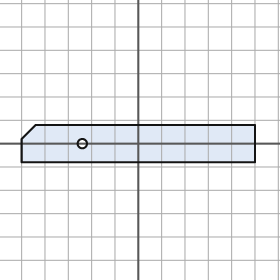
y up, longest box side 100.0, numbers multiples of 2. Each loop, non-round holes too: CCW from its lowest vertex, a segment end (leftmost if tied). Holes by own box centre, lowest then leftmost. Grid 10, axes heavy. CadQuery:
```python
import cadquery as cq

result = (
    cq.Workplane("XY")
    .moveTo(-50.0, -8.0)
    .lineTo(50.0, -8.0)
    .lineTo(50.0, 8.0)
    .lineTo(-44.0, 8.0)
    .lineTo(-50.0, 2.0)
    .close()
    .moveTo(-24.0, 0.0)
    .circle(2.0)
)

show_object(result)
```